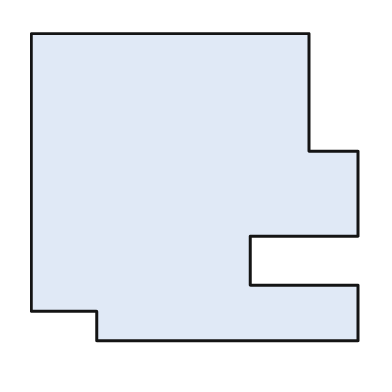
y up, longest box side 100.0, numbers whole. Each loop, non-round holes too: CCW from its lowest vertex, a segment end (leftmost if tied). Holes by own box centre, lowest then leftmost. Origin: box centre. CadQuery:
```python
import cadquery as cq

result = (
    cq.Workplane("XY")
    .moveTo(-30.0, -47.0)
    .lineTo(50.0, -47.0)
    .lineTo(50.0, -30.0)
    .lineTo(17.0, -30.0)
    .lineTo(17.0, -15.0)
    .lineTo(50.0, -15.0)
    .lineTo(50.0, 11.0)
    .lineTo(35.0, 11.0)
    .lineTo(35.0, 47.0)
    .lineTo(-50.0, 47.0)
    .lineTo(-50.0, -38.0)
    .lineTo(-30.0, -38.0)
    .close()
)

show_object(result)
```